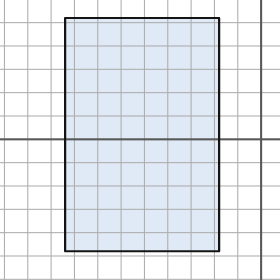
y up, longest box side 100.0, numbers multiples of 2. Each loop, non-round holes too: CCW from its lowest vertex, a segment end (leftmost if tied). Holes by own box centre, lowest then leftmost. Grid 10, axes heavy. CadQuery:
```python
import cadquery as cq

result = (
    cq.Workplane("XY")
    .moveTo(-84.0, -48.0)
    .lineTo(-18.0, -48.0)
    .lineTo(-18.0, 52.0)
    .lineTo(-84.0, 52.0)
    .close()
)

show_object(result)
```